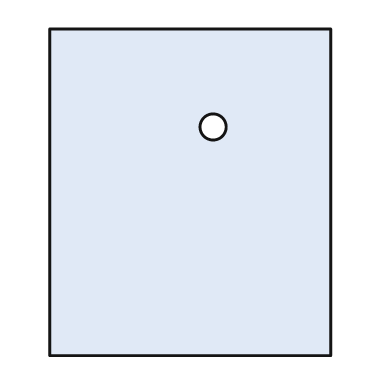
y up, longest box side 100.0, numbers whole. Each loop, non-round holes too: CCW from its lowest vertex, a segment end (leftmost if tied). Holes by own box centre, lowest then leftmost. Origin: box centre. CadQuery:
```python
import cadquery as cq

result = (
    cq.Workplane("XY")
    .moveTo(-43.0, -50.0)
    .lineTo(43.0, -50.0)
    .lineTo(43.0, 50.0)
    .lineTo(-43.0, 50.0)
    .close()
    .moveTo(7.0, 20.0)
    .circle(4.0)
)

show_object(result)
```